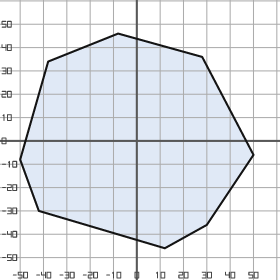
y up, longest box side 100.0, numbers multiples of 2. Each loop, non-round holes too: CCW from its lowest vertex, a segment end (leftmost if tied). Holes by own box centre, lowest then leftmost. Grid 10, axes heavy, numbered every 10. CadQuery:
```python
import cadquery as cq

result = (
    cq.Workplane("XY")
    .moveTo(12.0, -46.0)
    .lineTo(30.0, -36.0)
    .lineTo(50.0, -6.0)
    .lineTo(28.0, 36.0)
    .lineTo(-8.0, 46.0)
    .lineTo(-38.0, 34.0)
    .lineTo(-50.0, -8.0)
    .lineTo(-42.0, -30.0)
    .close()
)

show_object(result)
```